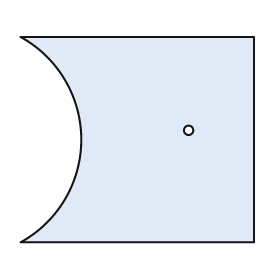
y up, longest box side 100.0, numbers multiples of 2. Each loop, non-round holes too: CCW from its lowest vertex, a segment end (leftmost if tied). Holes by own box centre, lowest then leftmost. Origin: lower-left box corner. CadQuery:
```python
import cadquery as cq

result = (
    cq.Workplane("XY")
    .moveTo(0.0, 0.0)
    .lineTo(100.0, 0.0)
    .lineTo(100.0, 88.0)
    .lineTo(0.0, 88.0)
    .threePointArc((26.0, 44.0), (0.0, 0.0))
    .close()
    .moveTo(72.0, 48.0)
    .circle(2.0)
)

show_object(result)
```